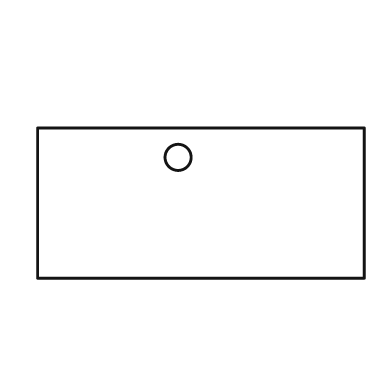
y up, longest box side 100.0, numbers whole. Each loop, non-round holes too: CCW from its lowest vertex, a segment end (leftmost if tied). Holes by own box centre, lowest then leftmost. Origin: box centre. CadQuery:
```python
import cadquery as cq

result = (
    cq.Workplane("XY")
    .moveTo(-50.0, -23.0)
    .lineTo(50.0, -23.0)
    .lineTo(50.0, 23.0)
    .lineTo(-50.0, 23.0)
    .close()
    .moveTo(-7.0, 14.0)
    .circle(4.0)
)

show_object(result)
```